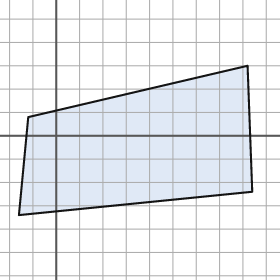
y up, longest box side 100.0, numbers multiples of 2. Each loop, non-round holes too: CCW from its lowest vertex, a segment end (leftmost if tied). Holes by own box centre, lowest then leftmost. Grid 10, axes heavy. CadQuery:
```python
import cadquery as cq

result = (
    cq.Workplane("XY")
    .moveTo(-16.0, -34.0)
    .lineTo(84.0, -24.0)
    .lineTo(82.0, 30.0)
    .lineTo(-12.0, 8.0)
    .close()
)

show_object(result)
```